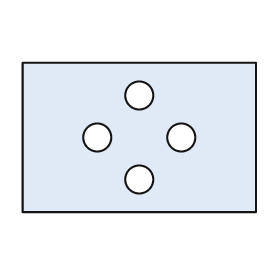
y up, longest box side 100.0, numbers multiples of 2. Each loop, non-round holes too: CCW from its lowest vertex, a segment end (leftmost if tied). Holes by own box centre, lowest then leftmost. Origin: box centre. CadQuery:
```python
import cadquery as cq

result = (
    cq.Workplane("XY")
    .moveTo(-50.0, -32.0)
    .lineTo(50.0, -32.0)
    .lineTo(50.0, 32.0)
    .lineTo(-50.0, 32.0)
    .close()
    .moveTo(0.0, -18.0)
    .circle(6.0)
    .moveTo(-18.0, 0.0)
    .circle(6.0)
    .moveTo(18.0, 0.0)
    .circle(6.0)
    .moveTo(0.0, 18.0)
    .circle(6.0)
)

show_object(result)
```